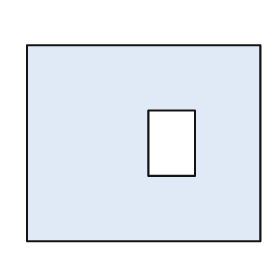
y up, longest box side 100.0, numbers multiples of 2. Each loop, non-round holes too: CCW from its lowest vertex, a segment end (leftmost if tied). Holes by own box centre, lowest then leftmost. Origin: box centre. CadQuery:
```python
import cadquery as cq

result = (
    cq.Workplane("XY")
    .moveTo(-50.0, -42.0)
    .lineTo(50.0, -42.0)
    .lineTo(50.0, 42.0)
    .lineTo(-50.0, 42.0)
    .close()
    .moveTo(2.0, -14.0)
    .lineTo(22.0, -14.0)
    .lineTo(22.0, 14.0)
    .lineTo(2.0, 14.0)
    .close()
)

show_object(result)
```